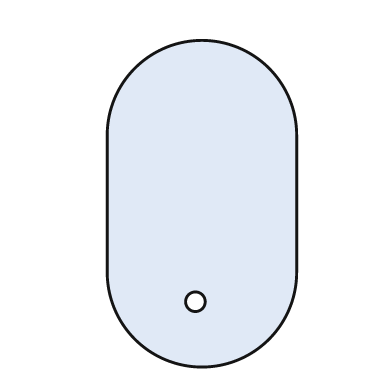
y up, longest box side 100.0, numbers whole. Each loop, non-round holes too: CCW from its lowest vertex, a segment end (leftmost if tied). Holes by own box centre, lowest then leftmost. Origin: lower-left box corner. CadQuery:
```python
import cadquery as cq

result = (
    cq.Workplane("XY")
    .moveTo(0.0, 29.0)
    .threePointArc((29.0, 0.0), (58.0, 29.0))
    .lineTo(58.0, 71.0)
    .threePointArc((29.0, 100.0), (0.0, 71.0))
    .close()
    .moveTo(27.0, 20.0)
    .circle(3.0)
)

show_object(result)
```